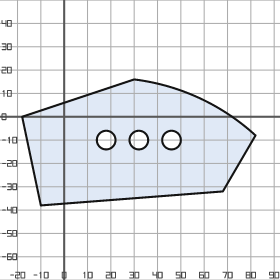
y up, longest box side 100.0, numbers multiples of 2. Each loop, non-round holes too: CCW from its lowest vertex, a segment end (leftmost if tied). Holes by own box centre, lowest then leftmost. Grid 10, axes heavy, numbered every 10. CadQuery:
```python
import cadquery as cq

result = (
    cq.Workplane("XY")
    .moveTo(-10.0, -38.0)
    .lineTo(68.0, -32.0)
    .lineTo(82.0, -8.0)
    .threePointArc((58.0, 8.0), (30.0, 16.0))
    .lineTo(-18.0, 0.0)
    .close()
    .moveTo(18.0, -10.0)
    .circle(4.0)
    .moveTo(32.0, -10.0)
    .circle(4.0)
    .moveTo(46.0, -10.0)
    .circle(4.0)
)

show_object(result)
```